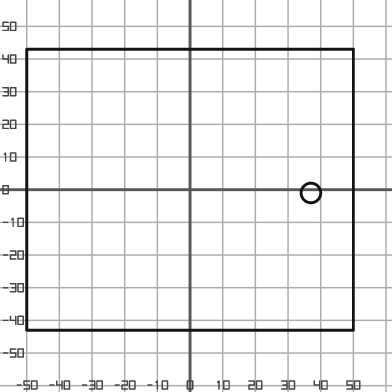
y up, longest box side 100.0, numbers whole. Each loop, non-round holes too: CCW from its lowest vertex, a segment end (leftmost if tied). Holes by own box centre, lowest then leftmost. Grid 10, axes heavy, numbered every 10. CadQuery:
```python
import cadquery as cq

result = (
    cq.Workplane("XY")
    .moveTo(-50.0, -43.0)
    .lineTo(50.0, -43.0)
    .lineTo(50.0, 43.0)
    .lineTo(-50.0, 43.0)
    .close()
    .moveTo(37.0, -1.0)
    .circle(3.0)
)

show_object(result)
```